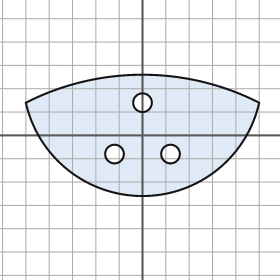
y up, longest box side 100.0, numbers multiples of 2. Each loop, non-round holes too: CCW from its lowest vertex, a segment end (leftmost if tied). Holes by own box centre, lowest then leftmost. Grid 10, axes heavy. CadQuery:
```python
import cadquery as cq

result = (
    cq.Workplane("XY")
    .moveTo(-50.0, 14.0)
    .threePointArc((0.0, -26.0), (50.0, 14.0))
    .threePointArc((0.0, 26.0), (-50.0, 14.0))
    .close()
    .moveTo(-12.0, -8.0)
    .circle(4.0)
    .moveTo(12.0, -8.0)
    .circle(4.0)
    .moveTo(0.0, 14.0)
    .circle(4.0)
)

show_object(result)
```